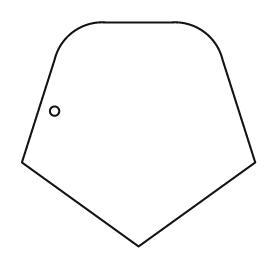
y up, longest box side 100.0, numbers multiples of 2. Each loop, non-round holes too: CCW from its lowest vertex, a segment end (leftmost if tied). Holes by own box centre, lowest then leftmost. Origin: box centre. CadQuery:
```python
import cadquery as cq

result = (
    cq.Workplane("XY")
    .moveTo(0.0, -48.0)
    .lineTo(50.0, -12.0)
    .lineTo(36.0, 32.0)
    .threePointArc((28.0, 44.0), (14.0, 48.0))
    .lineTo(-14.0, 48.0)
    .threePointArc((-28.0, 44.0), (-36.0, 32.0))
    .lineTo(-50.0, -12.0)
    .close()
    .moveTo(-36.0, 10.0)
    .circle(2.0)
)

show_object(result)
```